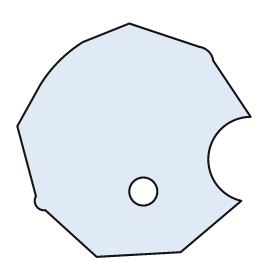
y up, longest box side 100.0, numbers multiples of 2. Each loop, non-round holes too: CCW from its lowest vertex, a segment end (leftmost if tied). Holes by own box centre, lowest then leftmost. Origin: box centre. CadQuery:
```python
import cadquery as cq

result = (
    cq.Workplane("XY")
    .moveTo(-16.0, -50.0)
    .lineTo(20.0, -48.0)
    .lineTo(46.0, -26.0)
    .threePointArc((32.0, -6.0), (50.0, 10.0))
    .lineTo(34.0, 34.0)
    .threePointArc((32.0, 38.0), (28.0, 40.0))
    .lineTo(-2.0, 50.0)
    .lineTo(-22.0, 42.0)
    .threePointArc((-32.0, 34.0), (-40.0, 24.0))
    .lineTo(-50.0, 6.0)
    .lineTo(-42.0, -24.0)
    .threePointArc((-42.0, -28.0), (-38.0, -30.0))
    .close()
    .moveTo(4.0, -22.0)
    .circle(6.0)
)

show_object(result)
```